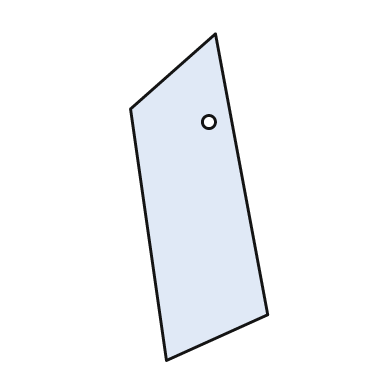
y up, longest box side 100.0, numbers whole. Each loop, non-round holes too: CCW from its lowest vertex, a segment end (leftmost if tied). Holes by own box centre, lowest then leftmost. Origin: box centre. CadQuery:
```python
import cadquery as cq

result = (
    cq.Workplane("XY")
    .moveTo(-10.0, -50.0)
    .lineTo(21.0, -36.0)
    .lineTo(5.0, 50.0)
    .lineTo(-21.0, 27.0)
    .close()
    .moveTo(3.0, 23.0)
    .circle(2.0)
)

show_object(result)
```